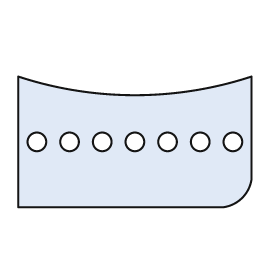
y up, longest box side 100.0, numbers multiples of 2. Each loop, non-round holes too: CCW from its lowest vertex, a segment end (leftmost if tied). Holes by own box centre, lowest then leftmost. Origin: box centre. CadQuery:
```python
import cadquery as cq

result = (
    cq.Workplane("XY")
    .moveTo(-50.0, -28.0)
    .lineTo(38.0, -28.0)
    .threePointArc((46.0, -24.0), (50.0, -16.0))
    .lineTo(50.0, 28.0)
    .threePointArc((0.0, 20.0), (-50.0, 28.0))
    .close()
    .moveTo(-42.0, 0.0)
    .circle(4.0)
    .moveTo(-28.0, 0.0)
    .circle(4.0)
    .moveTo(-14.0, 0.0)
    .circle(4.0)
    .moveTo(0.0, 0.0)
    .circle(4.0)
    .moveTo(14.0, 0.0)
    .circle(4.0)
    .moveTo(28.0, 0.0)
    .circle(4.0)
    .moveTo(42.0, 0.0)
    .circle(4.0)
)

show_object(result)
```